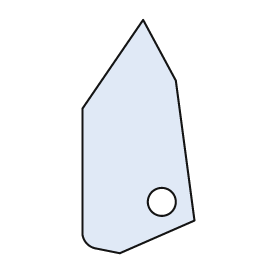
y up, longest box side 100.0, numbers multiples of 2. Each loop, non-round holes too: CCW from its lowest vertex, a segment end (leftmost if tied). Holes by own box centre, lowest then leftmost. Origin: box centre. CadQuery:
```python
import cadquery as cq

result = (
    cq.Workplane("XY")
    .moveTo(-8.0, -50.0)
    .lineTo(24.0, -36.0)
    .lineTo(16.0, 24.0)
    .lineTo(2.0, 50.0)
    .lineTo(-24.0, 12.0)
    .lineTo(-24.0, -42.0)
    .threePointArc((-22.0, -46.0), (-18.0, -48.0))
    .close()
    .moveTo(10.0, -28.0)
    .circle(6.0)
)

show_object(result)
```